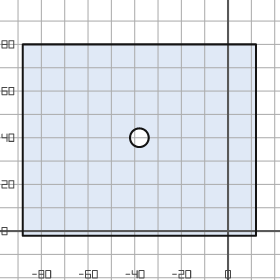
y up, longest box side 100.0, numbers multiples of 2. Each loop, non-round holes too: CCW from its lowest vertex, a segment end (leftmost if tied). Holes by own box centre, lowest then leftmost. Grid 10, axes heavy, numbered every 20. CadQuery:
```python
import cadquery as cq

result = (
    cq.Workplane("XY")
    .moveTo(-88.0, -2.0)
    .lineTo(12.0, -2.0)
    .lineTo(12.0, 80.0)
    .lineTo(-88.0, 80.0)
    .close()
    .moveTo(-38.0, 40.0)
    .circle(4.0)
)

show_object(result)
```